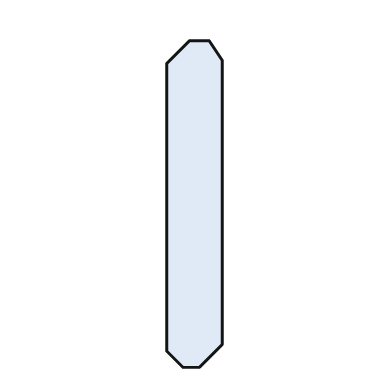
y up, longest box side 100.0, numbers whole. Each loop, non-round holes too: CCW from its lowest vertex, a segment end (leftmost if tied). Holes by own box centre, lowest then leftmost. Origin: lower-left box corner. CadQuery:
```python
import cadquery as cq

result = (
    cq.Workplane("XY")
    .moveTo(5.0, 0.0)
    .lineTo(10.0, 0.0)
    .lineTo(17.0, 7.0)
    .lineTo(17.0, 94.0)
    .lineTo(13.0, 100.0)
    .lineTo(7.0, 100.0)
    .lineTo(0.0, 93.0)
    .lineTo(0.0, 5.0)
    .close()
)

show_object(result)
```